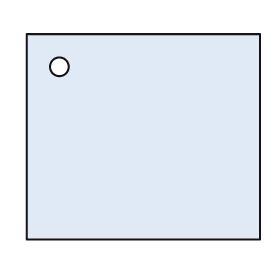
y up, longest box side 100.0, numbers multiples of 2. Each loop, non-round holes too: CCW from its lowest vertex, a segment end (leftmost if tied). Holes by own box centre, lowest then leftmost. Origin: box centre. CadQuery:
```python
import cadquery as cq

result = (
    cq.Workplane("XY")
    .moveTo(-50.0, -44.0)
    .lineTo(50.0, -44.0)
    .lineTo(50.0, 44.0)
    .lineTo(-50.0, 44.0)
    .close()
    .moveTo(-36.0, 30.0)
    .circle(4.0)
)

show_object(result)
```